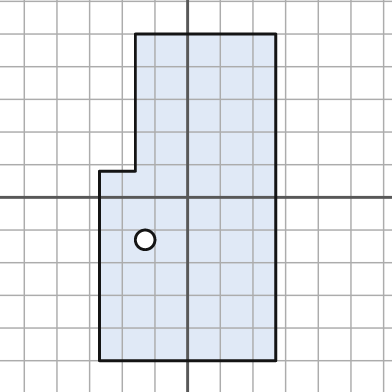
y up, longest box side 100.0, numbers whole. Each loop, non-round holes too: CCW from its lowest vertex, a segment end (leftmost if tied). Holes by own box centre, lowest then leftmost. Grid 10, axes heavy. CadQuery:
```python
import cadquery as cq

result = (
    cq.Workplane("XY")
    .moveTo(-27.0, -50.0)
    .lineTo(27.0, -50.0)
    .lineTo(27.0, 50.0)
    .lineTo(-16.0, 50.0)
    .lineTo(-16.0, 8.0)
    .lineTo(-27.0, 8.0)
    .close()
    .moveTo(-13.0, -13.0)
    .circle(3.0)
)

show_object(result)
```